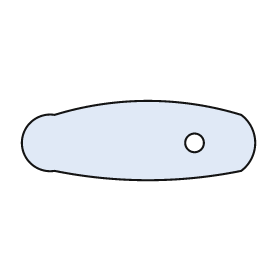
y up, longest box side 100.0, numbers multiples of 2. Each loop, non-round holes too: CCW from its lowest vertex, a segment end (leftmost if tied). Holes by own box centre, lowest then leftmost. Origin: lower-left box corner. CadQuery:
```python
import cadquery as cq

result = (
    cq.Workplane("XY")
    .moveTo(14.0, 4.0)
    .threePointArc((54.0, 0.0), (94.0, 4.0))
    .threePointArc((100.0, 16.0), (94.0, 28.0))
    .threePointArc((54.0, 34.0), (14.0, 28.0))
    .threePointArc((0.0, 16.0), (14.0, 4.0))
    .close()
    .moveTo(74.0, 16.0)
    .circle(4.0)
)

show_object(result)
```